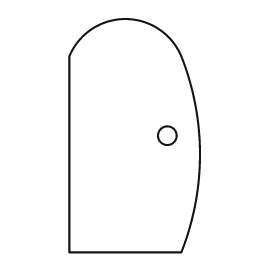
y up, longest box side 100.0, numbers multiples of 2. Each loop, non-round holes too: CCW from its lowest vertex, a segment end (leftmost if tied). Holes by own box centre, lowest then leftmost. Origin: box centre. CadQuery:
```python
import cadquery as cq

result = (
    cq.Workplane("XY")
    .moveTo(-28.0, -50.0)
    .lineTo(20.0, -50.0)
    .threePointArc((28.0, -8.0), (20.0, 34.0))
    .threePointArc((-4.0, 50.0), (-28.0, 34.0))
    .close()
    .moveTo(14.0, 0.0)
    .circle(4.0)
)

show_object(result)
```